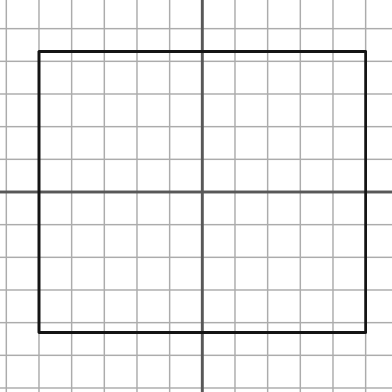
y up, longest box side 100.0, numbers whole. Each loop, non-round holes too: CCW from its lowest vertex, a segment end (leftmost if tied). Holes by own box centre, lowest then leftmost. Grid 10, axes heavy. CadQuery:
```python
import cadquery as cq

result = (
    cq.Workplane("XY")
    .moveTo(-50.0, -43.0)
    .lineTo(50.0, -43.0)
    .lineTo(50.0, 43.0)
    .lineTo(-50.0, 43.0)
    .close()
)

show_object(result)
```